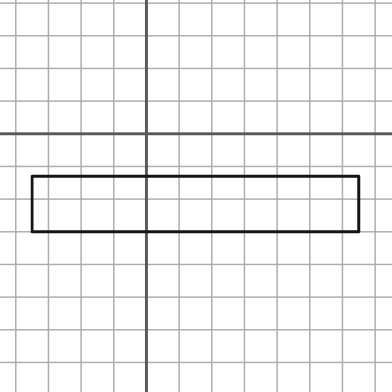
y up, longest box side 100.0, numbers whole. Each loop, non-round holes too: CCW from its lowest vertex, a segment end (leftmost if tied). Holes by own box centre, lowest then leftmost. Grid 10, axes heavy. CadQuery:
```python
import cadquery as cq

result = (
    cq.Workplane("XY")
    .moveTo(-35.0, -30.0)
    .lineTo(65.0, -30.0)
    .lineTo(65.0, -13.0)
    .lineTo(-35.0, -13.0)
    .close()
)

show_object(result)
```